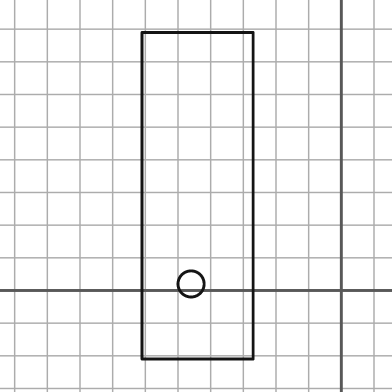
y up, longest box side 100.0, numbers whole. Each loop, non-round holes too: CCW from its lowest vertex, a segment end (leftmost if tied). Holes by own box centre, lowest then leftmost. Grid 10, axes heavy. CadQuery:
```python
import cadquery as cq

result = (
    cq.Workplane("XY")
    .moveTo(-61.0, -21.0)
    .lineTo(-27.0, -21.0)
    .lineTo(-27.0, 79.0)
    .lineTo(-61.0, 79.0)
    .close()
    .moveTo(-46.0, 2.0)
    .circle(4.0)
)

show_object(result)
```